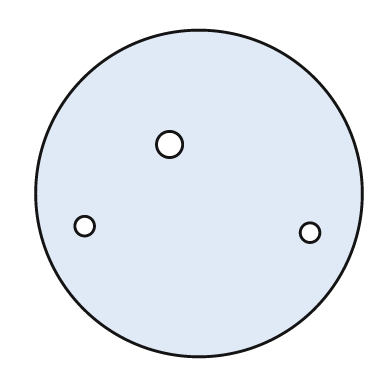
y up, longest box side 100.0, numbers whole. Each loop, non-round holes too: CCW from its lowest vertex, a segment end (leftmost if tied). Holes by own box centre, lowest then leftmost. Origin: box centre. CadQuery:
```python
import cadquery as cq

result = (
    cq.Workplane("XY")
    .moveTo(0.0, 0.0)
    .circle(50.0)
    .moveTo(34.0, -12.0)
    .circle(3.0)
    .moveTo(-35.0, -10.0)
    .circle(3.0)
    .moveTo(-9.0, 15.0)
    .circle(4.0)
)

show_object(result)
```